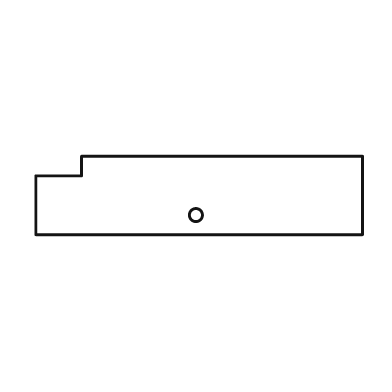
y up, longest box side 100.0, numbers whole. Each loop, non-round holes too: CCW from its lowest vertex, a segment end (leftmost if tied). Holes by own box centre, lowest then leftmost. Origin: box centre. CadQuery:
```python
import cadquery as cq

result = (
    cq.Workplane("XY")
    .moveTo(-50.0, -12.0)
    .lineTo(50.0, -12.0)
    .lineTo(50.0, 12.0)
    .lineTo(-36.0, 12.0)
    .lineTo(-36.0, 6.0)
    .lineTo(-50.0, 6.0)
    .close()
    .moveTo(-1.0, -6.0)
    .circle(2.0)
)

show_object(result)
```